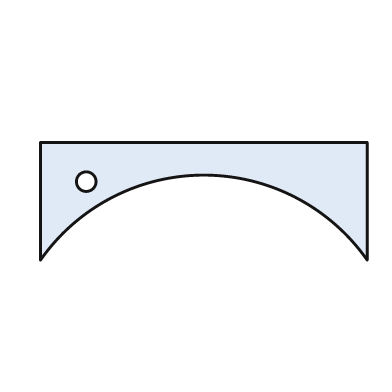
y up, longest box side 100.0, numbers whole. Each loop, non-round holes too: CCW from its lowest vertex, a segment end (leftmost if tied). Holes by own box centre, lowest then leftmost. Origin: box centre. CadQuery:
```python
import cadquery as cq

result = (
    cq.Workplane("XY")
    .moveTo(-50.0, -18.0)
    .threePointArc((0.0, 8.0), (50.0, -18.0))
    .lineTo(50.0, 18.0)
    .lineTo(-50.0, 18.0)
    .close()
    .moveTo(-36.0, 6.0)
    .circle(3.0)
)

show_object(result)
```